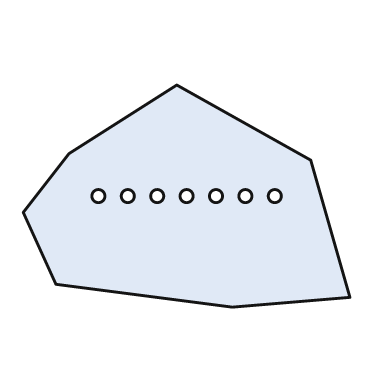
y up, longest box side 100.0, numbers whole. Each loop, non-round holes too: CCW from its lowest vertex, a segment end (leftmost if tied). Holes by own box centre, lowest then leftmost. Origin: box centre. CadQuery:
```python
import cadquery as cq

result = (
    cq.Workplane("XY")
    .moveTo(14.0, -34.0)
    .lineTo(50.0, -31.0)
    .lineTo(38.0, 11.0)
    .lineTo(-3.0, 34.0)
    .lineTo(-36.0, 13.0)
    .lineTo(-50.0, -5.0)
    .lineTo(-40.0, -27.0)
    .close()
    .moveTo(-27.0, 0.0)
    .circle(2.0)
    .moveTo(-18.0, 0.0)
    .circle(2.0)
    .moveTo(-9.0, 0.0)
    .circle(2.0)
    .moveTo(0.0, 0.0)
    .circle(2.0)
    .moveTo(9.0, 0.0)
    .circle(2.0)
    .moveTo(18.0, 0.0)
    .circle(2.0)
    .moveTo(27.0, 0.0)
    .circle(2.0)
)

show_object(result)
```